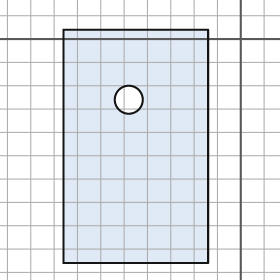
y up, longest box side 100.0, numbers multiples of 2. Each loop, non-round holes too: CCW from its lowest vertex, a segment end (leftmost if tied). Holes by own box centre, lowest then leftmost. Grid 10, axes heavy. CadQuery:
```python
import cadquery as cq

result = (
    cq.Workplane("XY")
    .moveTo(-76.0, -96.0)
    .lineTo(-14.0, -96.0)
    .lineTo(-14.0, 4.0)
    .lineTo(-76.0, 4.0)
    .close()
    .moveTo(-48.0, -26.0)
    .circle(6.0)
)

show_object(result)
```